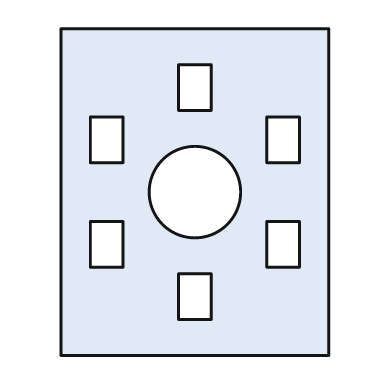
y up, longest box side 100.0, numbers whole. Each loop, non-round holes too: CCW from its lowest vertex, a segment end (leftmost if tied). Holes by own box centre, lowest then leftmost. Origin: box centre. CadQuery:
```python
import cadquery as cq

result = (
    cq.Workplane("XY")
    .moveTo(-41.0, -50.0)
    .lineTo(41.0, -50.0)
    .lineTo(41.0, 50.0)
    .lineTo(-41.0, 50.0)
    .close()
    .moveTo(-5.0, -39.0)
    .lineTo(5.0, -39.0)
    .lineTo(5.0, -25.0)
    .lineTo(-5.0, -25.0)
    .close()
    .moveTo(-32.0, -23.0)
    .lineTo(-22.0, -23.0)
    .lineTo(-22.0, -9.0)
    .lineTo(-32.0, -9.0)
    .close()
    .moveTo(22.0, -23.0)
    .lineTo(32.0, -23.0)
    .lineTo(32.0, -9.0)
    .lineTo(22.0, -9.0)
    .close()
    .moveTo(0.0, 0.0)
    .circle(14.0)
    .moveTo(-32.0, 9.0)
    .lineTo(-22.0, 9.0)
    .lineTo(-22.0, 23.0)
    .lineTo(-32.0, 23.0)
    .close()
    .moveTo(22.0, 9.0)
    .lineTo(32.0, 9.0)
    .lineTo(32.0, 23.0)
    .lineTo(22.0, 23.0)
    .close()
    .moveTo(-5.0, 25.0)
    .lineTo(5.0, 25.0)
    .lineTo(5.0, 39.0)
    .lineTo(-5.0, 39.0)
    .close()
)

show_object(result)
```